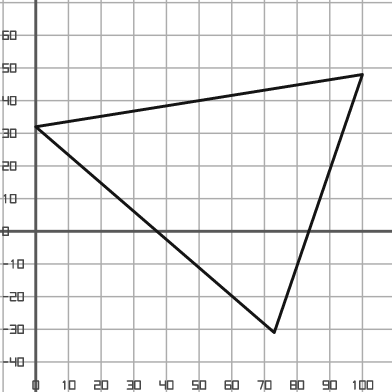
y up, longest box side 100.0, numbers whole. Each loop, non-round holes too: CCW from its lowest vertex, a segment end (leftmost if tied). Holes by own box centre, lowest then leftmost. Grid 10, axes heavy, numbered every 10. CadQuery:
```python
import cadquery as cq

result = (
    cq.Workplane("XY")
    .moveTo(73.0, -31.0)
    .lineTo(100.0, 48.0)
    .lineTo(0.0, 32.0)
    .close()
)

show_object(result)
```